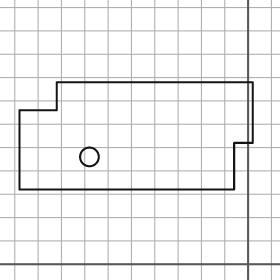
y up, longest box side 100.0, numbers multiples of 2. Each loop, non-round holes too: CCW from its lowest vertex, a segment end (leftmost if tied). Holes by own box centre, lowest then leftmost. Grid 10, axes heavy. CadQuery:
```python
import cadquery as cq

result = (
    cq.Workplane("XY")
    .moveTo(-98.0, 32.0)
    .lineTo(-6.0, 32.0)
    .lineTo(-6.0, 52.0)
    .lineTo(2.0, 52.0)
    .lineTo(2.0, 78.0)
    .lineTo(-82.0, 78.0)
    .lineTo(-82.0, 66.0)
    .lineTo(-98.0, 66.0)
    .close()
    .moveTo(-68.0, 46.0)
    .circle(4.0)
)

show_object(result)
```